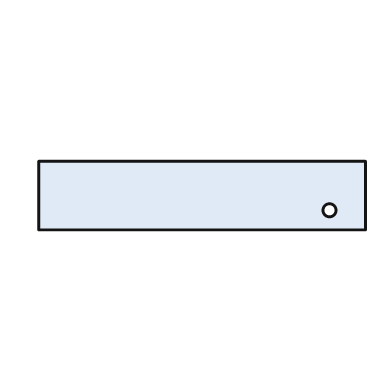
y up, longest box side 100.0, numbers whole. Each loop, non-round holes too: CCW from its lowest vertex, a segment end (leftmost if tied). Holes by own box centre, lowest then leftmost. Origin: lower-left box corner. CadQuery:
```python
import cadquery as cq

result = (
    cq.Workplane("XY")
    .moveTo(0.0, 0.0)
    .lineTo(100.0, 0.0)
    .lineTo(100.0, 21.0)
    .lineTo(0.0, 21.0)
    .close()
    .moveTo(89.0, 6.0)
    .circle(2.0)
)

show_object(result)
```